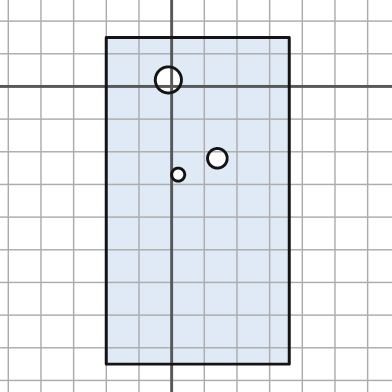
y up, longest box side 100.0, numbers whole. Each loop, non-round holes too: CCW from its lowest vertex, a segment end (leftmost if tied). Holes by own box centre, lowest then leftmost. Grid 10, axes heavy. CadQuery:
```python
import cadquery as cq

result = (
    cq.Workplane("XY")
    .moveTo(-20.0, -85.0)
    .lineTo(36.0, -85.0)
    .lineTo(36.0, 15.0)
    .lineTo(-20.0, 15.0)
    .close()
    .moveTo(2.0, -27.0)
    .circle(2.0)
    .moveTo(14.0, -22.0)
    .circle(3.0)
    .moveTo(-1.0, 2.0)
    .circle(4.0)
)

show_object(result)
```